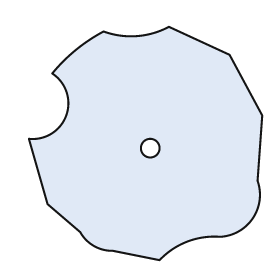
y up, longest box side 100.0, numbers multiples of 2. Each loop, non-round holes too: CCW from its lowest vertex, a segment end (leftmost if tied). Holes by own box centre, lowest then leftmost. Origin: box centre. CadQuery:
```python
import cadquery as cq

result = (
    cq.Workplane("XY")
    .moveTo(6.0, -50.0)
    .threePointArc((18.0, -42.0), (32.0, -40.0))
    .threePointArc((46.0, -32.0), (48.0, -16.0))
    .lineTo(50.0, 12.0)
    .lineTo(36.0, 38.0)
    .lineTo(10.0, 50.0)
    .threePointArc((-4.0, 46.0), (-18.0, 48.0))
    .threePointArc((-30.0, 40.0), (-40.0, 30.0))
    .threePointArc((-34.0, 12.0), (-50.0, 2.0))
    .lineTo(-42.0, -26.0)
    .lineTo(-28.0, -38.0)
    .threePointArc((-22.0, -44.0), (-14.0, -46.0))
    .close()
    .moveTo(2.0, -2.0)
    .circle(4.0)
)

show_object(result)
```